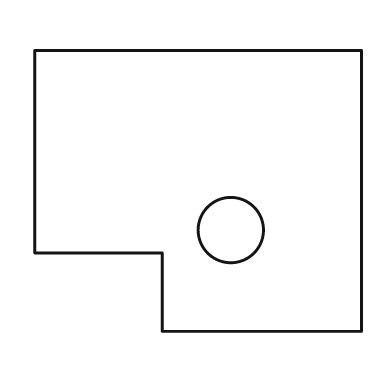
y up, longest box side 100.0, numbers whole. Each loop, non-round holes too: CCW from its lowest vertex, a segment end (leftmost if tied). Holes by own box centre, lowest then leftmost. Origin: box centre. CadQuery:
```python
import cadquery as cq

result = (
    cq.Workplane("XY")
    .moveTo(-11.0, -43.0)
    .lineTo(50.0, -43.0)
    .lineTo(50.0, 43.0)
    .lineTo(-50.0, 43.0)
    .lineTo(-50.0, -19.0)
    .lineTo(-11.0, -19.0)
    .close()
    .moveTo(10.0, -12.0)
    .circle(10.0)
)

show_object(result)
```